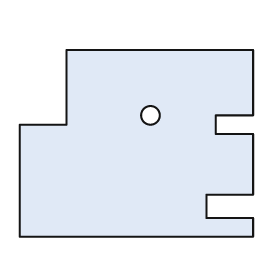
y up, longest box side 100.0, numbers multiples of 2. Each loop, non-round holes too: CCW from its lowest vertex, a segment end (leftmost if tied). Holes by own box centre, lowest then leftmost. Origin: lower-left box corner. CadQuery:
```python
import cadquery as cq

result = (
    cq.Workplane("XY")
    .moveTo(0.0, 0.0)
    .lineTo(100.0, 0.0)
    .lineTo(100.0, 8.0)
    .lineTo(80.0, 8.0)
    .lineTo(80.0, 18.0)
    .lineTo(100.0, 18.0)
    .lineTo(100.0, 44.0)
    .lineTo(84.0, 44.0)
    .lineTo(84.0, 52.0)
    .lineTo(100.0, 52.0)
    .lineTo(100.0, 80.0)
    .lineTo(20.0, 80.0)
    .lineTo(20.0, 48.0)
    .lineTo(0.0, 48.0)
    .close()
    .moveTo(56.0, 52.0)
    .circle(4.0)
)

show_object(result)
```